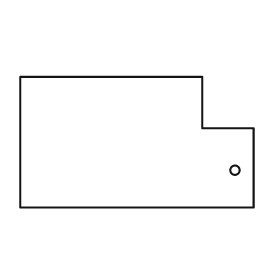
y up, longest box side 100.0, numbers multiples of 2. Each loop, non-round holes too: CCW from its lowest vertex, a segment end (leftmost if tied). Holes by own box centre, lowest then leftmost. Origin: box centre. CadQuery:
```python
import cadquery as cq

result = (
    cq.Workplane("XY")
    .moveTo(-50.0, -28.0)
    .lineTo(50.0, -28.0)
    .lineTo(50.0, 6.0)
    .lineTo(28.0, 6.0)
    .lineTo(28.0, 28.0)
    .lineTo(-50.0, 28.0)
    .close()
    .moveTo(42.0, -12.0)
    .circle(2.0)
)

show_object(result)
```